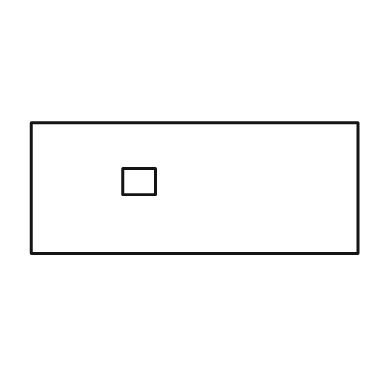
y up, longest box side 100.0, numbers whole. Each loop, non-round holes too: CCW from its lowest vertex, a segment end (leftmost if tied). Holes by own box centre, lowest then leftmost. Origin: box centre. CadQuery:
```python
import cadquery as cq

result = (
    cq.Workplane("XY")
    .moveTo(-50.0, -20.0)
    .lineTo(50.0, -20.0)
    .lineTo(50.0, 20.0)
    .lineTo(-50.0, 20.0)
    .close()
    .moveTo(-22.0, -2.0)
    .lineTo(-12.0, -2.0)
    .lineTo(-12.0, 6.0)
    .lineTo(-22.0, 6.0)
    .close()
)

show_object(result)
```